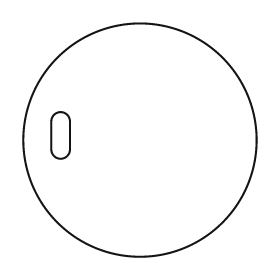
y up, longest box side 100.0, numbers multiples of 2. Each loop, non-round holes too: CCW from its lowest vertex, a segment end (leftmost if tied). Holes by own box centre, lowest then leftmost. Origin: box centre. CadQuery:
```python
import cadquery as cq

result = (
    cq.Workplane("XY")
    .moveTo(0.0, 0.0)
    .circle(50.0)
    .moveTo(-38.0, -4.0)
    .threePointArc((-34.0, -8.0), (-30.0, -4.0))
    .lineTo(-30.0, 8.0)
    .threePointArc((-34.0, 12.0), (-38.0, 8.0))
    .close()
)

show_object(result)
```